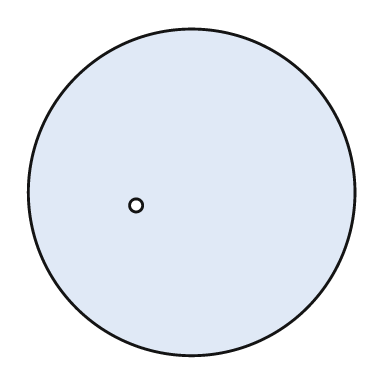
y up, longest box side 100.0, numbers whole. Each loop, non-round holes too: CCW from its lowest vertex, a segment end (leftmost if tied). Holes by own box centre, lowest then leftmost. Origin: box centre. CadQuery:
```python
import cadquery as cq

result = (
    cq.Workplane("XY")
    .moveTo(0.0, 0.0)
    .circle(50.0)
    .moveTo(-17.0, -4.0)
    .circle(2.0)
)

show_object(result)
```